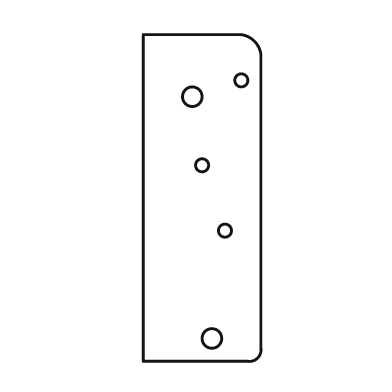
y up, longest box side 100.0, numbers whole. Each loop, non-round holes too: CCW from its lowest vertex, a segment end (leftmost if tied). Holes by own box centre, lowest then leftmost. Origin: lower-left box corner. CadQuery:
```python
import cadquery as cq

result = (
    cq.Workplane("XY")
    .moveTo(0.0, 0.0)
    .lineTo(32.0, 0.0)
    .threePointArc((35.0, 1.0), (36.0, 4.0))
    .lineTo(36.0, 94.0)
    .threePointArc((34.0, 98.0), (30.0, 100.0))
    .lineTo(0.0, 100.0)
    .close()
    .moveTo(21.0, 7.0)
    .circle(3.0)
    .moveTo(25.0, 40.0)
    .circle(2.0)
    .moveTo(18.0, 60.0)
    .circle(2.0)
    .moveTo(15.0, 81.0)
    .circle(3.0)
    .moveTo(30.0, 86.0)
    .circle(2.0)
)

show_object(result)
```